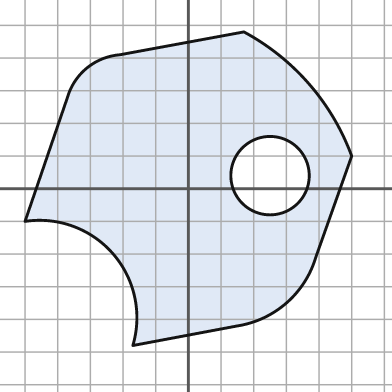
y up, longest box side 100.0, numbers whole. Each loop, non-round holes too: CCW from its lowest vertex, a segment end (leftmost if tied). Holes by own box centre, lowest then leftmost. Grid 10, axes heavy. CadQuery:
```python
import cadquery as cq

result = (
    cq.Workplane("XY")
    .moveTo(-17.0, -48.0)
    .lineTo(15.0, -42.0)
    .threePointArc((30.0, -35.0), (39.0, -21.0))
    .lineTo(50.0, 10.0)
    .threePointArc((37.0, 32.0), (17.0, 48.0))
    .lineTo(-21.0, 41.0)
    .threePointArc((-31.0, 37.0), (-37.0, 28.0))
    .lineTo(-50.0, -10.0)
    .threePointArc((-23.0, -20.0), (-17.0, -48.0))
    .close()
    .moveTo(25.0, 4.0)
    .circle(12.0)
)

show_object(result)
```